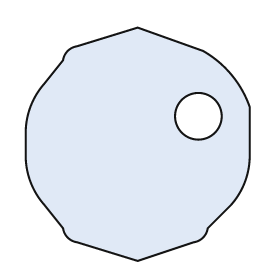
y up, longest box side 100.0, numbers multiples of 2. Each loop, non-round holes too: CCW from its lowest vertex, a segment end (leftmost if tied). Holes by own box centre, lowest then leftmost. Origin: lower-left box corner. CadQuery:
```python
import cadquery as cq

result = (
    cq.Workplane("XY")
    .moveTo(48.0, 0.0)
    .lineTo(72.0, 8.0)
    .threePointArc((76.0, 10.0), (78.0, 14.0))
    .lineTo(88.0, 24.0)
    .threePointArc((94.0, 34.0), (96.0, 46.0))
    .lineTo(96.0, 66.0)
    .threePointArc((88.0, 80.0), (76.0, 90.0))
    .lineTo(48.0, 100.0)
    .lineTo(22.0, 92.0)
    .threePointArc((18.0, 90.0), (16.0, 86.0))
    .lineTo(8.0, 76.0)
    .threePointArc((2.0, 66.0), (0.0, 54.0))
    .lineTo(0.0, 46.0)
    .threePointArc((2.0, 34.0), (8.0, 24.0))
    .lineTo(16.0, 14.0)
    .threePointArc((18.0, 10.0), (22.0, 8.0))
    .close()
    .moveTo(74.0, 62.0)
    .circle(10.0)
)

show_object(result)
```